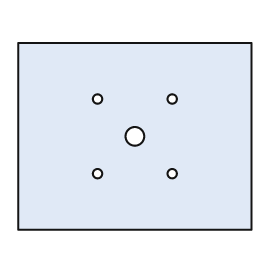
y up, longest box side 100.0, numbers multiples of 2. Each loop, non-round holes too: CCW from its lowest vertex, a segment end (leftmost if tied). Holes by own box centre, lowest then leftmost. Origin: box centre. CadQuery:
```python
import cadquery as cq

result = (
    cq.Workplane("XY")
    .moveTo(-50.0, -40.0)
    .lineTo(50.0, -40.0)
    .lineTo(50.0, 40.0)
    .lineTo(-50.0, 40.0)
    .close()
    .moveTo(-16.0, -16.0)
    .circle(2.0)
    .moveTo(16.0, -16.0)
    .circle(2.0)
    .moveTo(0.0, 0.0)
    .circle(4.0)
    .moveTo(-16.0, 16.0)
    .circle(2.0)
    .moveTo(16.0, 16.0)
    .circle(2.0)
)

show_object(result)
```